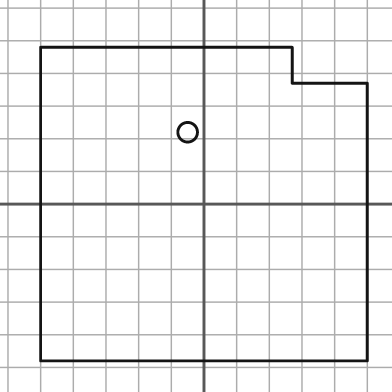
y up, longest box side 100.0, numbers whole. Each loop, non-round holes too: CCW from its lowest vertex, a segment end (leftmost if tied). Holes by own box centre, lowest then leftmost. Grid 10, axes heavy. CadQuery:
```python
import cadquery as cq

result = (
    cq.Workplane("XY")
    .moveTo(-50.0, -48.0)
    .lineTo(50.0, -48.0)
    .lineTo(50.0, 37.0)
    .lineTo(27.0, 37.0)
    .lineTo(27.0, 48.0)
    .lineTo(-50.0, 48.0)
    .close()
    .moveTo(-5.0, 22.0)
    .circle(3.0)
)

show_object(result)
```